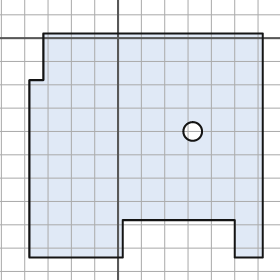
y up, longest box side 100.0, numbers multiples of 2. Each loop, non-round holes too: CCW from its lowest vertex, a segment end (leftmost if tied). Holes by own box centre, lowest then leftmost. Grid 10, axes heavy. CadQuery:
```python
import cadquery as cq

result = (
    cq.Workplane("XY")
    .moveTo(-38.0, -94.0)
    .lineTo(2.0, -94.0)
    .lineTo(2.0, -78.0)
    .lineTo(50.0, -78.0)
    .lineTo(50.0, -94.0)
    .lineTo(62.0, -94.0)
    .lineTo(62.0, 2.0)
    .lineTo(-32.0, 2.0)
    .lineTo(-32.0, -18.0)
    .lineTo(-38.0, -18.0)
    .close()
    .moveTo(32.0, -40.0)
    .circle(4.0)
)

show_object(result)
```